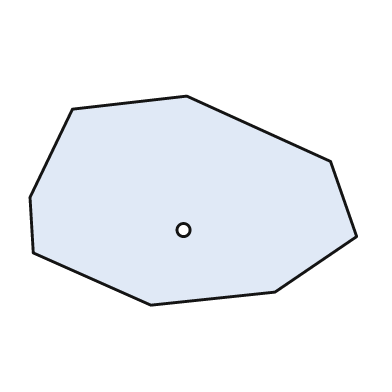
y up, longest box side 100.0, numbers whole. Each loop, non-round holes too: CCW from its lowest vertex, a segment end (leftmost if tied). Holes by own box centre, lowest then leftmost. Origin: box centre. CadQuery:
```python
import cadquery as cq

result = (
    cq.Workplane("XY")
    .moveTo(-13.0, -32.0)
    .lineTo(25.0, -28.0)
    .lineTo(50.0, -11.0)
    .lineTo(42.0, 12.0)
    .lineTo(-2.0, 32.0)
    .lineTo(-37.0, 28.0)
    .lineTo(-50.0, 1.0)
    .lineTo(-49.0, -16.0)
    .close()
    .moveTo(-3.0, -9.0)
    .circle(2.0)
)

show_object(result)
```